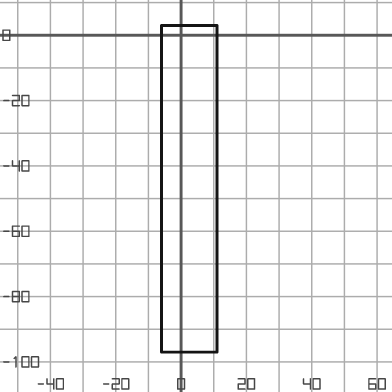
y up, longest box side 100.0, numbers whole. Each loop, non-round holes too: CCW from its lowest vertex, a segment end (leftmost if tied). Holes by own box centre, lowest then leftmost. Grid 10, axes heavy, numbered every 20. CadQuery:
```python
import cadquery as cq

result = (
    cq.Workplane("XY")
    .moveTo(-6.0, -97.0)
    .lineTo(11.0, -97.0)
    .lineTo(11.0, 3.0)
    .lineTo(-6.0, 3.0)
    .close()
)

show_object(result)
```